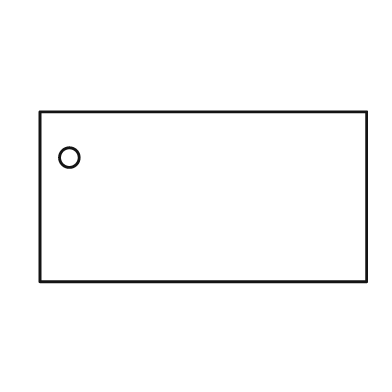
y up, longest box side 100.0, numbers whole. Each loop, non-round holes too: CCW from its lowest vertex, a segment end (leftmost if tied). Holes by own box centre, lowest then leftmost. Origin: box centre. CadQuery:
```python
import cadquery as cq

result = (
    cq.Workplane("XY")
    .moveTo(-50.0, -26.0)
    .lineTo(50.0, -26.0)
    .lineTo(50.0, 26.0)
    .lineTo(-50.0, 26.0)
    .close()
    .moveTo(-41.0, 12.0)
    .circle(3.0)
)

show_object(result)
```